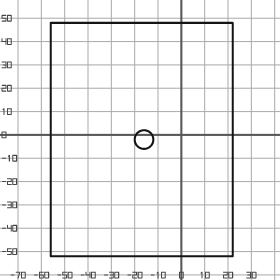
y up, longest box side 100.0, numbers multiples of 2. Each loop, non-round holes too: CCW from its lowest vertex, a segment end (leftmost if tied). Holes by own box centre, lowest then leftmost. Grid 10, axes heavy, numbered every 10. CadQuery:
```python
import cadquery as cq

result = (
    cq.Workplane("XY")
    .moveTo(-56.0, -52.0)
    .lineTo(22.0, -52.0)
    .lineTo(22.0, 48.0)
    .lineTo(-56.0, 48.0)
    .close()
    .moveTo(-16.0, -2.0)
    .circle(4.0)
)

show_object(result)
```